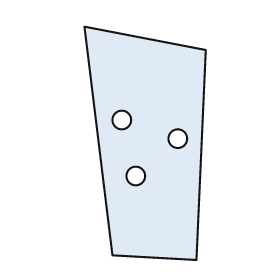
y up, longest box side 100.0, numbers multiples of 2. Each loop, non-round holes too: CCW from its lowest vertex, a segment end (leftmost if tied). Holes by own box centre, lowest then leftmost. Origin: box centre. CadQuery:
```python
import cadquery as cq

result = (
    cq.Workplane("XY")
    .moveTo(22.0, -50.0)
    .lineTo(26.0, 40.0)
    .lineTo(-26.0, 50.0)
    .lineTo(-14.0, -48.0)
    .close()
    .moveTo(-4.0, -14.0)
    .circle(4.0)
    .moveTo(14.0, 2.0)
    .circle(4.0)
    .moveTo(-10.0, 10.0)
    .circle(4.0)
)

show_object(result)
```